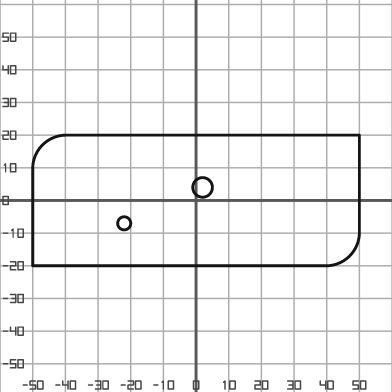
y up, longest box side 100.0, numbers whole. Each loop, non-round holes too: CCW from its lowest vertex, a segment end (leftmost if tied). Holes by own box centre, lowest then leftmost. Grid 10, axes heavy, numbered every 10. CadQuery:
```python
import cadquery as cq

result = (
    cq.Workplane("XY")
    .moveTo(-50.0, -20.0)
    .lineTo(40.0, -20.0)
    .threePointArc((47.0, -17.0), (50.0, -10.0))
    .lineTo(50.0, 20.0)
    .lineTo(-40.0, 20.0)
    .threePointArc((-47.0, 17.0), (-50.0, 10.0))
    .close()
    .moveTo(-22.0, -7.0)
    .circle(2.0)
    .moveTo(2.0, 4.0)
    .circle(3.0)
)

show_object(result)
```